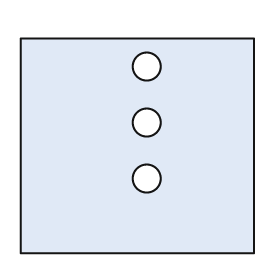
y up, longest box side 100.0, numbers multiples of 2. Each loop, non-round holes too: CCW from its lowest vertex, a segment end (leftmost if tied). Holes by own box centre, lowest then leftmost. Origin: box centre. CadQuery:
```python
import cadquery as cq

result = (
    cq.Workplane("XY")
    .moveTo(-50.0, -46.0)
    .lineTo(50.0, -46.0)
    .lineTo(50.0, 46.0)
    .lineTo(-50.0, 46.0)
    .close()
    .moveTo(4.0, -14.0)
    .circle(6.0)
    .moveTo(4.0, 10.0)
    .circle(6.0)
    .moveTo(4.0, 34.0)
    .circle(6.0)
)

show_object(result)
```